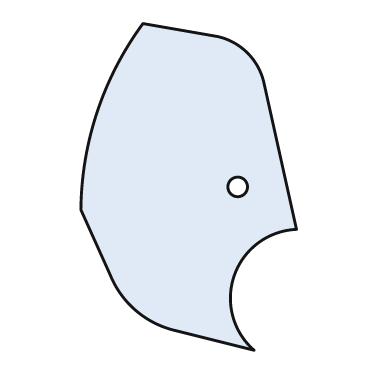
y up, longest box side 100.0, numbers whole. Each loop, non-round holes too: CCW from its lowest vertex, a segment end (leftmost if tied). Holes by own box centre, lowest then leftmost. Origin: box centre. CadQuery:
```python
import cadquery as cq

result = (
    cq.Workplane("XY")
    .moveTo(20.0, -50.0)
    .threePointArc((14.0, -27.0), (33.0, -13.0))
    .lineTo(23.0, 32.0)
    .threePointArc((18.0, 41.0), (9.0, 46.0))
    .lineTo(-14.0, 50.0)
    .threePointArc((-28.0, 23.0), (-33.0, -7.0))
    .lineTo(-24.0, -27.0)
    .threePointArc((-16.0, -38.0), (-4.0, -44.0))
    .close()
    .moveTo(15.0, 0.0)
    .circle(3.0)
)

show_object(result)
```